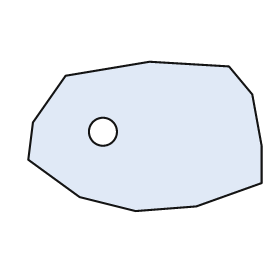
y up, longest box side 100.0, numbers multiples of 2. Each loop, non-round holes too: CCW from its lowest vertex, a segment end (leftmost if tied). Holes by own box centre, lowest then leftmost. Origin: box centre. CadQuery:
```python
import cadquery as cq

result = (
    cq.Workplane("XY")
    .moveTo(-4.0, -32.0)
    .lineTo(22.0, -30.0)
    .lineTo(50.0, -20.0)
    .lineTo(50.0, -4.0)
    .lineTo(46.0, 18.0)
    .lineTo(36.0, 30.0)
    .lineTo(2.0, 32.0)
    .lineTo(-34.0, 26.0)
    .lineTo(-48.0, 6.0)
    .lineTo(-50.0, -10.0)
    .lineTo(-28.0, -26.0)
    .close()
    .moveTo(-18.0, 2.0)
    .circle(6.0)
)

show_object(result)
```